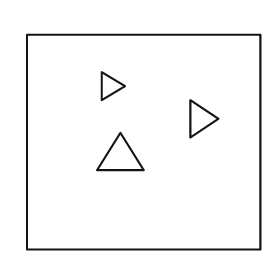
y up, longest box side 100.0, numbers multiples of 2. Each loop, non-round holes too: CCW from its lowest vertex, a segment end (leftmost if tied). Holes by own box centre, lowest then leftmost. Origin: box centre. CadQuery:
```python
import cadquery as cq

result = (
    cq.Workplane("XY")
    .moveTo(-50.0, -46.0)
    .lineTo(50.0, -46.0)
    .lineTo(50.0, 46.0)
    .lineTo(-50.0, 46.0)
    .close()
    .moveTo(-20.0, -12.0)
    .lineTo(0.0, -12.0)
    .lineTo(-10.0, 4.0)
    .close()
    .moveTo(20.0, 2.0)
    .lineTo(32.0, 10.0)
    .lineTo(20.0, 18.0)
    .close()
    .moveTo(-18.0, 18.0)
    .lineTo(-8.0, 24.0)
    .lineTo(-18.0, 30.0)
    .close()
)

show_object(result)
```